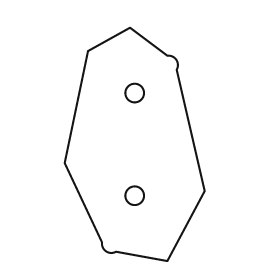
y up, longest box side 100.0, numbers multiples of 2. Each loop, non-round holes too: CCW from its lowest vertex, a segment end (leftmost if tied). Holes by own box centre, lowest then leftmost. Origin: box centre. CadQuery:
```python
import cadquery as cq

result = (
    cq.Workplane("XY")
    .moveTo(14.0, -50.0)
    .lineTo(30.0, -20.0)
    .lineTo(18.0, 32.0)
    .threePointArc((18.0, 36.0), (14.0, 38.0))
    .lineTo(-2.0, 50.0)
    .lineTo(-20.0, 40.0)
    .lineTo(-30.0, -8.0)
    .lineTo(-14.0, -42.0)
    .threePointArc((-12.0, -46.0), (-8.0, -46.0))
    .close()
    .moveTo(0.0, -22.0)
    .circle(4.0)
    .moveTo(0.0, 22.0)
    .circle(4.0)
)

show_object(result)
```